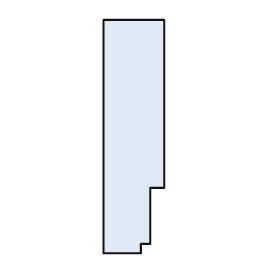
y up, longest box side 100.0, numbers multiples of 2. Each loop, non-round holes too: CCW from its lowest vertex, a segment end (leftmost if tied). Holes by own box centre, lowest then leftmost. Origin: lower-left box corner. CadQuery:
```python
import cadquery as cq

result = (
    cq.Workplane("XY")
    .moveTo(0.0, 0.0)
    .lineTo(16.0, 0.0)
    .lineTo(16.0, 4.0)
    .lineTo(20.0, 4.0)
    .lineTo(20.0, 28.0)
    .lineTo(26.0, 28.0)
    .lineTo(26.0, 100.0)
    .lineTo(0.0, 100.0)
    .close()
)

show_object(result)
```